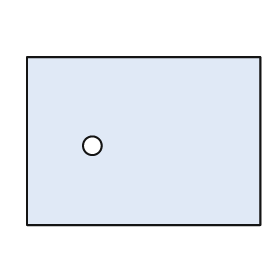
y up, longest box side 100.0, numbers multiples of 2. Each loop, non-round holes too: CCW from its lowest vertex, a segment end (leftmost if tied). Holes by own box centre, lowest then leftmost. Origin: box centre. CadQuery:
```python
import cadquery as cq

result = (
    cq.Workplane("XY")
    .moveTo(-50.0, -36.0)
    .lineTo(50.0, -36.0)
    .lineTo(50.0, 36.0)
    .lineTo(-50.0, 36.0)
    .close()
    .moveTo(-22.0, -2.0)
    .circle(4.0)
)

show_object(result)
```